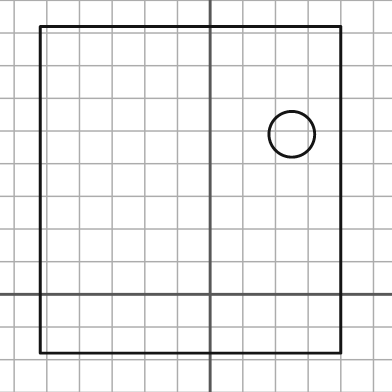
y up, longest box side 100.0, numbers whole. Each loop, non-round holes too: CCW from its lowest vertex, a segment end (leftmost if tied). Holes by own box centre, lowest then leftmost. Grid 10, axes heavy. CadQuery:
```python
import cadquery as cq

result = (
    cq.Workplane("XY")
    .moveTo(-52.0, -18.0)
    .lineTo(40.0, -18.0)
    .lineTo(40.0, 82.0)
    .lineTo(-52.0, 82.0)
    .close()
    .moveTo(25.0, 49.0)
    .circle(7.0)
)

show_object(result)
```